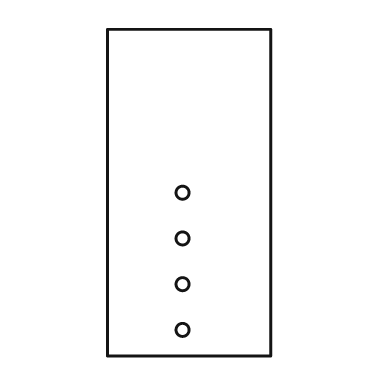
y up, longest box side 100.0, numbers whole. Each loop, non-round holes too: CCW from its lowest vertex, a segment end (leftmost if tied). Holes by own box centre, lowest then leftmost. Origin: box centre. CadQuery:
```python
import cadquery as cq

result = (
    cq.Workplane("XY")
    .moveTo(-25.0, -50.0)
    .lineTo(25.0, -50.0)
    .lineTo(25.0, 50.0)
    .lineTo(-25.0, 50.0)
    .close()
    .moveTo(-2.0, -42.0)
    .circle(2.0)
    .moveTo(-2.0, -28.0)
    .circle(2.0)
    .moveTo(-2.0, -14.0)
    .circle(2.0)
    .moveTo(-2.0, 0.0)
    .circle(2.0)
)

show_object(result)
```